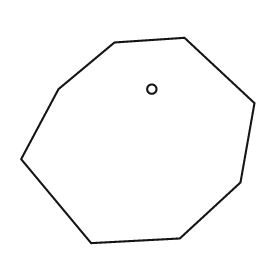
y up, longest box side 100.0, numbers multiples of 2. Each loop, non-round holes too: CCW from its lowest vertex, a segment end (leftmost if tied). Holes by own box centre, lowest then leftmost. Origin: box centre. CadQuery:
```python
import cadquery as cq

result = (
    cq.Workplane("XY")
    .moveTo(-20.0, -44.0)
    .lineTo(18.0, -42.0)
    .lineTo(44.0, -18.0)
    .lineTo(50.0, 16.0)
    .lineTo(20.0, 44.0)
    .lineTo(-10.0, 42.0)
    .lineTo(-34.0, 22.0)
    .lineTo(-50.0, -8.0)
    .close()
    .moveTo(6.0, 22.0)
    .circle(2.0)
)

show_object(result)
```